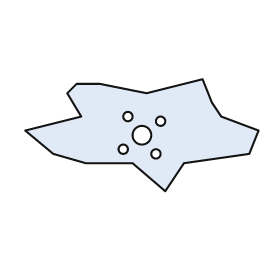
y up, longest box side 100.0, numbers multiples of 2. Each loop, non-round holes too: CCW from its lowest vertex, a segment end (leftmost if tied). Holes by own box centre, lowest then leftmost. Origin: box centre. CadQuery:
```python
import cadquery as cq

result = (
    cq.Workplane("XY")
    .moveTo(10.0, -24.0)
    .lineTo(18.0, -12.0)
    .lineTo(46.0, -8.0)
    .lineTo(50.0, 2.0)
    .lineTo(34.0, 8.0)
    .lineTo(30.0, 14.0)
    .lineTo(26.0, 24.0)
    .lineTo(2.0, 18.0)
    .lineTo(-18.0, 22.0)
    .lineTo(-28.0, 22.0)
    .lineTo(-32.0, 18.0)
    .lineTo(-26.0, 8.0)
    .lineTo(-50.0, 2.0)
    .lineTo(-38.0, -8.0)
    .lineTo(-24.0, -12.0)
    .lineTo(-4.0, -12.0)
    .close()
    .moveTo(6.0, -8.0)
    .circle(2.0)
    .moveTo(-8.0, -6.0)
    .circle(2.0)
    .moveTo(0.0, 0.0)
    .circle(4.0)
    .moveTo(8.0, 6.0)
    .circle(2.0)
    .moveTo(-6.0, 8.0)
    .circle(2.0)
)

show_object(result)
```